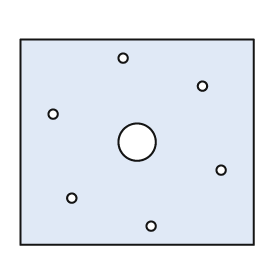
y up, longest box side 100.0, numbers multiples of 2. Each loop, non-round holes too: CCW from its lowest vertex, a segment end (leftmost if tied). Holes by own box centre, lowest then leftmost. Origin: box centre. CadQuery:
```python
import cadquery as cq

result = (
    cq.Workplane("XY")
    .moveTo(-50.0, -44.0)
    .lineTo(50.0, -44.0)
    .lineTo(50.0, 44.0)
    .lineTo(-50.0, 44.0)
    .close()
    .moveTo(6.0, -36.0)
    .circle(2.0)
    .moveTo(-28.0, -24.0)
    .circle(2.0)
    .moveTo(36.0, -12.0)
    .circle(2.0)
    .moveTo(0.0, 0.0)
    .circle(8.0)
    .moveTo(-36.0, 12.0)
    .circle(2.0)
    .moveTo(28.0, 24.0)
    .circle(2.0)
    .moveTo(-6.0, 36.0)
    .circle(2.0)
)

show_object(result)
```